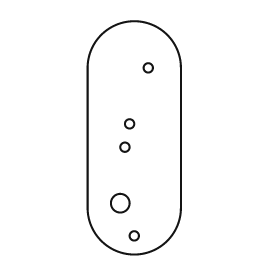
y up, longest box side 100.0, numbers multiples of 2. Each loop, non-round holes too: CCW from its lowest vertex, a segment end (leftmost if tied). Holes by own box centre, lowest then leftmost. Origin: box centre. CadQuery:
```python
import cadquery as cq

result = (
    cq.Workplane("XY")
    .moveTo(-20.0, -30.0)
    .threePointArc((0.0, -50.0), (20.0, -30.0))
    .lineTo(20.0, 30.0)
    .threePointArc((0.0, 50.0), (-20.0, 30.0))
    .close()
    .moveTo(0.0, -42.0)
    .circle(2.0)
    .moveTo(-6.0, -28.0)
    .circle(4.0)
    .moveTo(-4.0, -4.0)
    .circle(2.0)
    .moveTo(-2.0, 6.0)
    .circle(2.0)
    .moveTo(6.0, 30.0)
    .circle(2.0)
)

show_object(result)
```